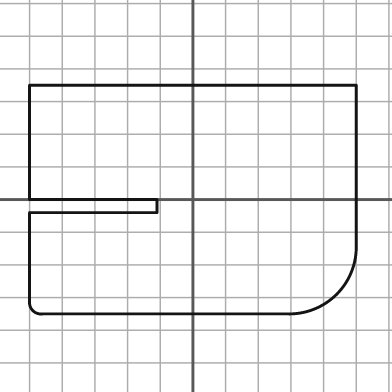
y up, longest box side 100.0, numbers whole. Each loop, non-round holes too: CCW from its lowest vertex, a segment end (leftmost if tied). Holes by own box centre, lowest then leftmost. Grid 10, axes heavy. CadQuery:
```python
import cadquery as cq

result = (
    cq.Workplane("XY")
    .moveTo(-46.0, -35.0)
    .lineTo(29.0, -35.0)
    .threePointArc((44.0, -29.0), (50.0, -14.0))
    .lineTo(50.0, 35.0)
    .lineTo(-50.0, 35.0)
    .lineTo(-50.0, 0.0)
    .lineTo(-11.0, 0.0)
    .lineTo(-11.0, -4.0)
    .lineTo(-50.0, -4.0)
    .lineTo(-50.0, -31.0)
    .threePointArc((-49.0, -34.0), (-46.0, -35.0))
    .close()
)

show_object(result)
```